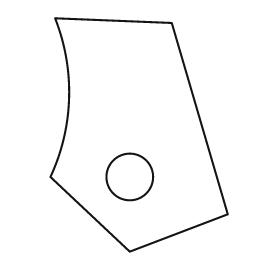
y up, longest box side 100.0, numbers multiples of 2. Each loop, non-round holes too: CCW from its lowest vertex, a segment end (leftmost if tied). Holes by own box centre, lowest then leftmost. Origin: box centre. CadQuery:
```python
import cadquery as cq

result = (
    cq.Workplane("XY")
    .moveTo(-4.0, -50.0)
    .lineTo(38.0, -34.0)
    .lineTo(14.0, 48.0)
    .lineTo(-36.0, 50.0)
    .threePointArc((-30.0, 16.0), (-38.0, -18.0))
    .close()
    .moveTo(-4.0, -18.0)
    .circle(10.0)
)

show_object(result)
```